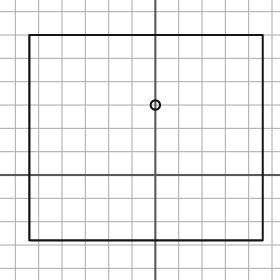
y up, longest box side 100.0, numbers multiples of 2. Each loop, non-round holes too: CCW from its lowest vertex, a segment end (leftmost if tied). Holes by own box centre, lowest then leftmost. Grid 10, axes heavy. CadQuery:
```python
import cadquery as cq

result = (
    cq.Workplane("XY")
    .moveTo(-54.0, -28.0)
    .lineTo(46.0, -28.0)
    .lineTo(46.0, 60.0)
    .lineTo(-54.0, 60.0)
    .close()
    .moveTo(0.0, 30.0)
    .circle(2.0)
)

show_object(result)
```